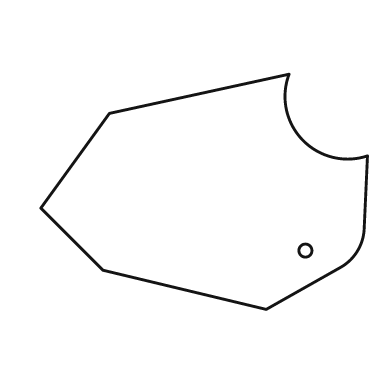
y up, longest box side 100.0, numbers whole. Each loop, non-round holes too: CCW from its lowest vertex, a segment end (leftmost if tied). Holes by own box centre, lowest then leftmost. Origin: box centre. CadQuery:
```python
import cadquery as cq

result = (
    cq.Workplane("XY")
    .moveTo(19.0, -36.0)
    .lineTo(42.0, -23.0)
    .threePointArc((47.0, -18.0), (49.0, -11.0))
    .lineTo(50.0, 11.0)
    .threePointArc((30.0, 16.0), (26.0, 36.0))
    .lineTo(-29.0, 24.0)
    .lineTo(-50.0, -5.0)
    .lineTo(-31.0, -24.0)
    .close()
    .moveTo(31.0, -18.0)
    .circle(2.0)
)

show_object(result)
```